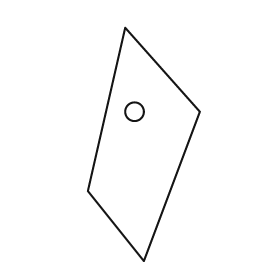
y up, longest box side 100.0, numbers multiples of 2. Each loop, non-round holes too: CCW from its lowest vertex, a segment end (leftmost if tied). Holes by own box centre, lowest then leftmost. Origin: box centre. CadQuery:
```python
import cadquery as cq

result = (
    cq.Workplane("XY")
    .moveTo(0.0, -50.0)
    .lineTo(24.0, 14.0)
    .lineTo(-8.0, 50.0)
    .lineTo(-24.0, -20.0)
    .close()
    .moveTo(-4.0, 14.0)
    .circle(4.0)
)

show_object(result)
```